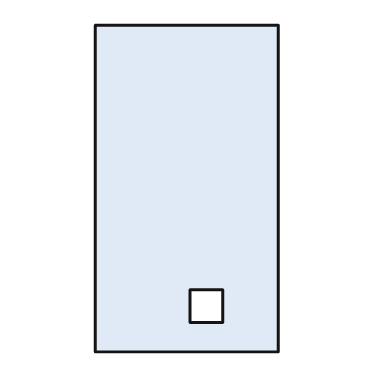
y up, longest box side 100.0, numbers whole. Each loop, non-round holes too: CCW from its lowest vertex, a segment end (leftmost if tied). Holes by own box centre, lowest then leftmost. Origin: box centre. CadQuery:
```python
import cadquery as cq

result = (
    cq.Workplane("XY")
    .moveTo(-28.0, -50.0)
    .lineTo(28.0, -50.0)
    .lineTo(28.0, 50.0)
    .lineTo(-28.0, 50.0)
    .close()
    .moveTo(1.0, -41.0)
    .lineTo(11.0, -41.0)
    .lineTo(11.0, -31.0)
    .lineTo(1.0, -31.0)
    .close()
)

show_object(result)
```